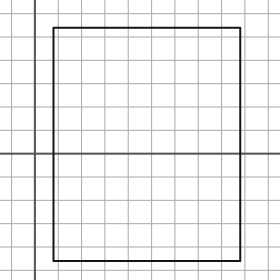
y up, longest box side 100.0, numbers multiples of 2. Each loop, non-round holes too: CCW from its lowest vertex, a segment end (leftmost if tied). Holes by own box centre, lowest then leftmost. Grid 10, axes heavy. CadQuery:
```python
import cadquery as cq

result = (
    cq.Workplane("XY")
    .moveTo(8.0, -46.0)
    .lineTo(88.0, -46.0)
    .lineTo(88.0, 54.0)
    .lineTo(8.0, 54.0)
    .close()
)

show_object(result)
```